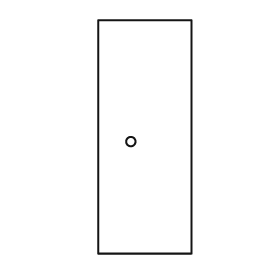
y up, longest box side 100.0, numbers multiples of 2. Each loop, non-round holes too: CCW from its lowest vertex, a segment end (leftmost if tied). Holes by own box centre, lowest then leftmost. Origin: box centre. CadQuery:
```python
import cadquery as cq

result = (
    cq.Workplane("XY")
    .moveTo(-20.0, -50.0)
    .lineTo(20.0, -50.0)
    .lineTo(20.0, 50.0)
    .lineTo(-20.0, 50.0)
    .close()
    .moveTo(-6.0, -2.0)
    .circle(2.0)
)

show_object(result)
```